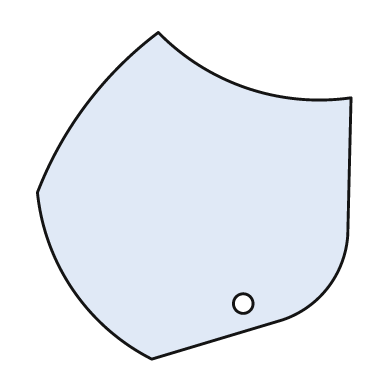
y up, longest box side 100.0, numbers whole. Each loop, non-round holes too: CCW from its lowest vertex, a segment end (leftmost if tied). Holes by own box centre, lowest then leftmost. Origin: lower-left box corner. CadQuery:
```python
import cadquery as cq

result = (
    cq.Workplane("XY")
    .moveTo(35.0, 0.0)
    .lineTo(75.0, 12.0)
    .threePointArc((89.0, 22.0), (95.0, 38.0))
    .lineTo(96.0, 80.0)
    .threePointArc((64.0, 83.0), (37.0, 100.0))
    .threePointArc((15.0, 78.0), (0.0, 51.0))
    .threePointArc((11.0, 21.0), (35.0, 0.0))
    .close()
    .moveTo(63.0, 17.0)
    .circle(3.0)
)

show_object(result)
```